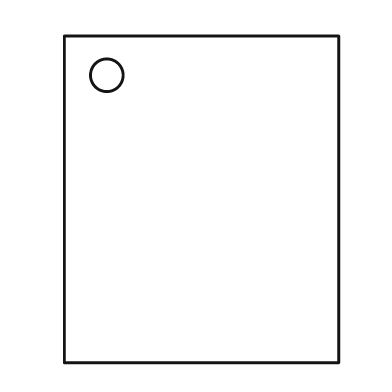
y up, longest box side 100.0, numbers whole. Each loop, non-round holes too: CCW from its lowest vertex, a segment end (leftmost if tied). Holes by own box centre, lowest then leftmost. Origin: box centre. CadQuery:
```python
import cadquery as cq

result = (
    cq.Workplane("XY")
    .moveTo(-42.0, -50.0)
    .lineTo(42.0, -50.0)
    .lineTo(42.0, 50.0)
    .lineTo(-42.0, 50.0)
    .close()
    .moveTo(-29.0, 38.0)
    .circle(5.0)
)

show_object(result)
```